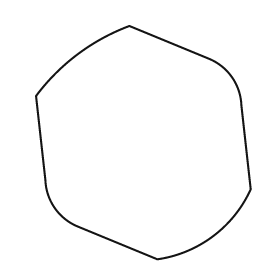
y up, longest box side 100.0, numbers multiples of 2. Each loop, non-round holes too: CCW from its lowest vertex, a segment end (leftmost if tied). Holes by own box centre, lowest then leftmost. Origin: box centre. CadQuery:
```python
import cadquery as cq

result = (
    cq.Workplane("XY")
    .moveTo(6.0, -50.0)
    .threePointArc((30.0, -40.0), (46.0, -20.0))
    .lineTo(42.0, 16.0)
    .threePointArc((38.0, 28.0), (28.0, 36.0))
    .lineTo(-6.0, 50.0)
    .threePointArc((-28.0, 38.0), (-46.0, 20.0))
    .lineTo(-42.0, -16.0)
    .threePointArc((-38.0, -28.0), (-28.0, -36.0))
    .close()
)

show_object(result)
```